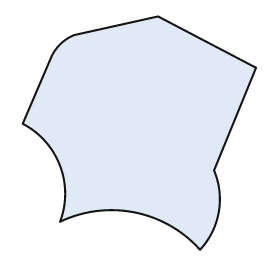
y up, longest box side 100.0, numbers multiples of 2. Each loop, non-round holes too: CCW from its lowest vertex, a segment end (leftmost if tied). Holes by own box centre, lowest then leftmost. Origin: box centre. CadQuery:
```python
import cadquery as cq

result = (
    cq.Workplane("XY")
    .moveTo(26.0, -50.0)
    .threePointArc((34.0, -34.0), (32.0, -16.0))
    .lineTo(50.0, 28.0)
    .lineTo(8.0, 50.0)
    .lineTo(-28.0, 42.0)
    .threePointArc((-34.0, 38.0), (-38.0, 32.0))
    .lineTo(-50.0, 4.0)
    .threePointArc((-34.0, -14.0), (-34.0, -38.0))
    .threePointArc((-2.0, -34.0), (26.0, -50.0))
    .close()
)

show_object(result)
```